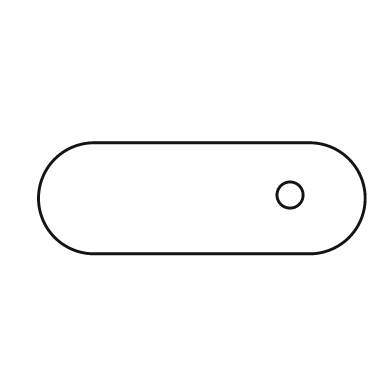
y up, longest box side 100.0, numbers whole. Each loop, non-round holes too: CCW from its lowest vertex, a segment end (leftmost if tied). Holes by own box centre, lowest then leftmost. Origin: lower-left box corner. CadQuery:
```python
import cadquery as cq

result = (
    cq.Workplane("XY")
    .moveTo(17.0, 0.0)
    .lineTo(83.0, 0.0)
    .threePointArc((100.0, 17.0), (83.0, 34.0))
    .lineTo(17.0, 34.0)
    .threePointArc((0.0, 17.0), (17.0, 0.0))
    .close()
    .moveTo(77.0, 18.0)
    .circle(4.0)
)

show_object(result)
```